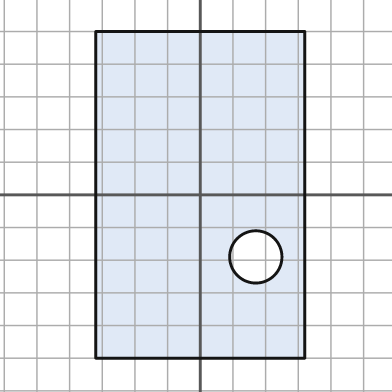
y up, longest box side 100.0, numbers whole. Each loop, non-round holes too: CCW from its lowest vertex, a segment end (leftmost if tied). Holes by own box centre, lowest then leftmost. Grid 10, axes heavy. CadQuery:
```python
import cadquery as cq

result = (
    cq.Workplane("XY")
    .moveTo(-32.0, -50.0)
    .lineTo(32.0, -50.0)
    .lineTo(32.0, 50.0)
    .lineTo(-32.0, 50.0)
    .close()
    .moveTo(17.0, -19.0)
    .circle(8.0)
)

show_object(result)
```